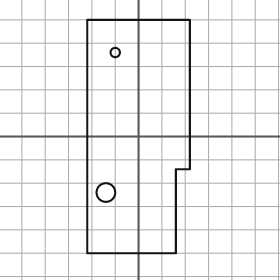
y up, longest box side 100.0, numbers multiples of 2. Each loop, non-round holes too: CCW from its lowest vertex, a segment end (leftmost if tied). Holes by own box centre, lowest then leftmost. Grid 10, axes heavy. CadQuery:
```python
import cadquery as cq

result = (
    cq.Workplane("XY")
    .moveTo(-22.0, -50.0)
    .lineTo(16.0, -50.0)
    .lineTo(16.0, -14.0)
    .lineTo(22.0, -14.0)
    .lineTo(22.0, 50.0)
    .lineTo(-22.0, 50.0)
    .close()
    .moveTo(-14.0, -24.0)
    .circle(4.0)
    .moveTo(-10.0, 36.0)
    .circle(2.0)
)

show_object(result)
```